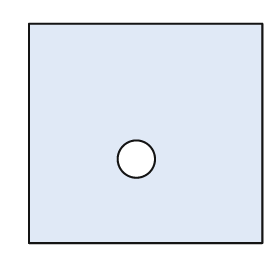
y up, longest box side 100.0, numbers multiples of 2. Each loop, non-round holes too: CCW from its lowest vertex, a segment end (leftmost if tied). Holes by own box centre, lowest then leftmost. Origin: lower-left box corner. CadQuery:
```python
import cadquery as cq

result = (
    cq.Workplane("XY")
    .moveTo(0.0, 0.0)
    .lineTo(100.0, 0.0)
    .lineTo(100.0, 94.0)
    .lineTo(0.0, 94.0)
    .close()
    .moveTo(46.0, 36.0)
    .circle(8.0)
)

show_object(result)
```